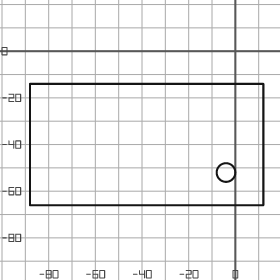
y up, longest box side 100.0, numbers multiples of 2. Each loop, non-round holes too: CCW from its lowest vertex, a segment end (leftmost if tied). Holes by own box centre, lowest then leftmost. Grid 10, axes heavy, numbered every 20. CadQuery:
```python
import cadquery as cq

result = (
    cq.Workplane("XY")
    .moveTo(-88.0, -66.0)
    .lineTo(12.0, -66.0)
    .lineTo(12.0, -14.0)
    .lineTo(-88.0, -14.0)
    .close()
    .moveTo(-4.0, -52.0)
    .circle(4.0)
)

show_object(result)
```